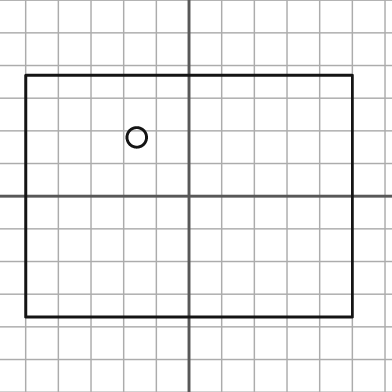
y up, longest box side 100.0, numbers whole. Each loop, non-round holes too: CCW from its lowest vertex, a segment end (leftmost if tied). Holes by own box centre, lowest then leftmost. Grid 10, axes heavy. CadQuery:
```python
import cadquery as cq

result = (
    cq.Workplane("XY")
    .moveTo(-50.0, -37.0)
    .lineTo(50.0, -37.0)
    .lineTo(50.0, 37.0)
    .lineTo(-50.0, 37.0)
    .close()
    .moveTo(-16.0, 18.0)
    .circle(3.0)
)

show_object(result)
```